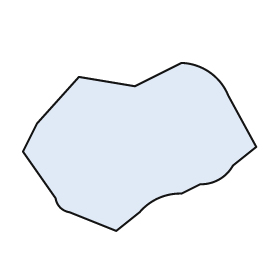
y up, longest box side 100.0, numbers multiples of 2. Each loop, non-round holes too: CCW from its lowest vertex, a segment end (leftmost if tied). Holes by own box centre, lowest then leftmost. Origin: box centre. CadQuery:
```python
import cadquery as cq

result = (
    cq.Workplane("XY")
    .moveTo(-10.0, -36.0)
    .lineTo(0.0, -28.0)
    .threePointArc((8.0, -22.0), (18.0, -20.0))
    .lineTo(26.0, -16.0)
    .threePointArc((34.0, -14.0), (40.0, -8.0))
    .lineTo(50.0, 0.0)
    .lineTo(38.0, 22.0)
    .threePointArc((30.0, 32.0), (18.0, 36.0))
    .lineTo(-2.0, 26.0)
    .lineTo(-26.0, 30.0)
    .lineTo(-44.0, 10.0)
    .lineTo(-50.0, -2.0)
    .lineTo(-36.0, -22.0)
    .threePointArc((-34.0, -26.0), (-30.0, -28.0))
    .close()
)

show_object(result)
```